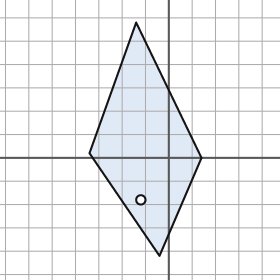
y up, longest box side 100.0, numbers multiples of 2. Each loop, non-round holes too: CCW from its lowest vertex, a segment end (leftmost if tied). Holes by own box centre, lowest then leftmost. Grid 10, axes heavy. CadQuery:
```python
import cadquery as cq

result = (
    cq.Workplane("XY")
    .moveTo(-4.0, -42.0)
    .lineTo(14.0, 0.0)
    .lineTo(-14.0, 58.0)
    .lineTo(-34.0, 2.0)
    .close()
    .moveTo(-12.0, -18.0)
    .circle(2.0)
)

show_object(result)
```